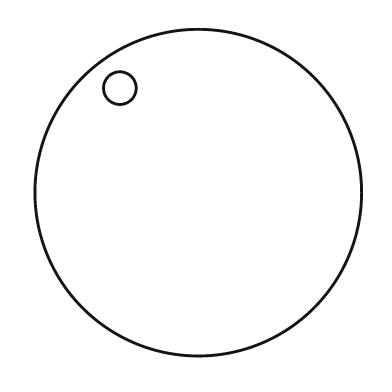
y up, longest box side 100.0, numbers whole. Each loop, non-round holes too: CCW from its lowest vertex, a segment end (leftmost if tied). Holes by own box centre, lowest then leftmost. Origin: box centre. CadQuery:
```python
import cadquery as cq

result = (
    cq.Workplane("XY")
    .moveTo(0.0, 0.0)
    .circle(50.0)
    .moveTo(-24.0, 32.0)
    .circle(5.0)
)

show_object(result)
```